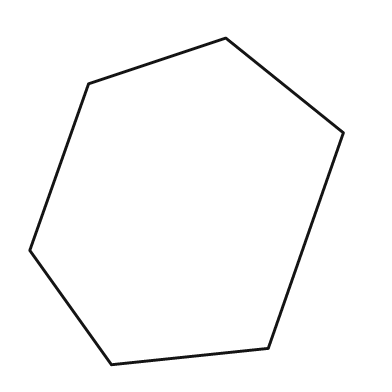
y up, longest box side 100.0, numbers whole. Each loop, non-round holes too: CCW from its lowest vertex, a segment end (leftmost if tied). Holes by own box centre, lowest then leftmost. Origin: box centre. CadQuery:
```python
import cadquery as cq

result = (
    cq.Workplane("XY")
    .moveTo(-23.0, -50.0)
    .lineTo(25.0, -45.0)
    .lineTo(48.0, 21.0)
    .lineTo(12.0, 50.0)
    .lineTo(-30.0, 36.0)
    .lineTo(-48.0, -15.0)
    .close()
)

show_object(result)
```